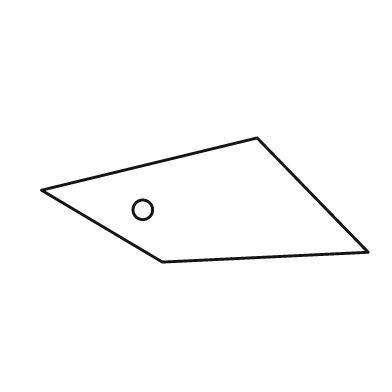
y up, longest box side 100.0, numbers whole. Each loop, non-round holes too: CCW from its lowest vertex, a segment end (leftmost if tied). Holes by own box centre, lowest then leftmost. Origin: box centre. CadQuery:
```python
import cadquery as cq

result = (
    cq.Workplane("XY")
    .moveTo(-13.0, -19.0)
    .lineTo(50.0, -16.0)
    .lineTo(16.0, 19.0)
    .lineTo(-50.0, 3.0)
    .close()
    .moveTo(-19.0, -3.0)
    .circle(3.0)
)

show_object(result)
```